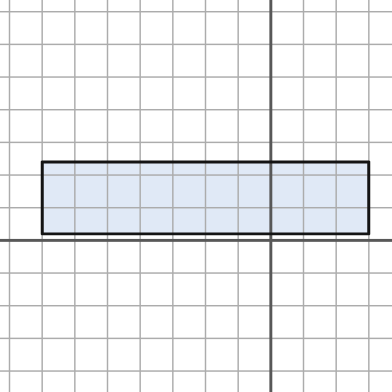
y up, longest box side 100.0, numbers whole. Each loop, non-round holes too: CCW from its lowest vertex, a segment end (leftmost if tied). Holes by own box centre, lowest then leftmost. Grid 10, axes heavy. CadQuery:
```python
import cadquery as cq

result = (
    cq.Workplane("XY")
    .moveTo(-70.0, 2.0)
    .lineTo(30.0, 2.0)
    .lineTo(30.0, 24.0)
    .lineTo(-70.0, 24.0)
    .close()
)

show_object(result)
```